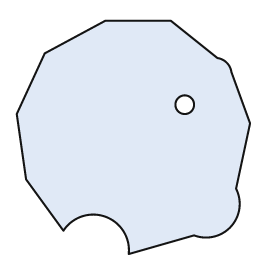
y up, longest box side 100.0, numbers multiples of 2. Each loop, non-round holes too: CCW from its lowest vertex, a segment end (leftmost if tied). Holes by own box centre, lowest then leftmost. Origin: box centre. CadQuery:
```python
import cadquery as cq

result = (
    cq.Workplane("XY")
    .moveTo(-2.0, -50.0)
    .lineTo(26.0, -42.0)
    .threePointArc((42.0, -38.0), (44.0, -22.0))
    .lineTo(50.0, 6.0)
    .lineTo(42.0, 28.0)
    .threePointArc((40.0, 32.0), (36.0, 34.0))
    .lineTo(16.0, 50.0)
    .lineTo(-12.0, 50.0)
    .lineTo(-38.0, 36.0)
    .lineTo(-50.0, 10.0)
    .lineTo(-46.0, -18.0)
    .lineTo(-30.0, -40.0)
    .threePointArc((-12.0, -34.0), (-2.0, -50.0))
    .close()
    .moveTo(22.0, 14.0)
    .circle(4.0)
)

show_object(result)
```